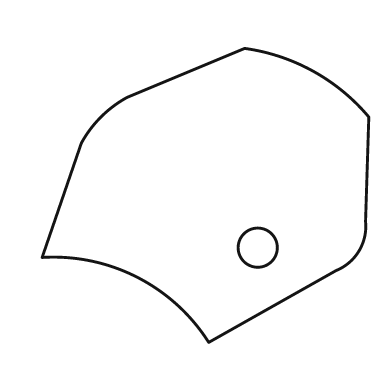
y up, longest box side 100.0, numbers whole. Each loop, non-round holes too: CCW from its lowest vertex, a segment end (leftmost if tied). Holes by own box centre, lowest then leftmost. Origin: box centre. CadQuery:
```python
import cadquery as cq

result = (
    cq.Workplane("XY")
    .moveTo(1.0, -45.0)
    .lineTo(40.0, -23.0)
    .threePointArc((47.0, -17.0), (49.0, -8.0))
    .lineTo(50.0, 24.0)
    .threePointArc((33.0, 38.0), (12.0, 45.0))
    .lineTo(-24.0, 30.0)
    .threePointArc((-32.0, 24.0), (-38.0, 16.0))
    .lineTo(-50.0, -19.0)
    .threePointArc((-21.0, -25.0), (1.0, -45.0))
    .close()
    .moveTo(16.0, -16.0)
    .circle(6.0)
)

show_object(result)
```